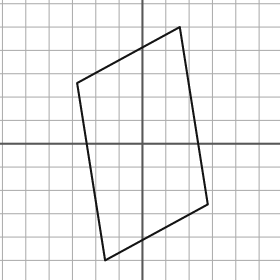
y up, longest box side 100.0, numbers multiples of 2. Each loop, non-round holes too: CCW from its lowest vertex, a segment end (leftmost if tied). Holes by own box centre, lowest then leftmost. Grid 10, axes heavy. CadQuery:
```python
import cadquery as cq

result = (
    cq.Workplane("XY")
    .moveTo(-16.0, -50.0)
    .lineTo(28.0, -26.0)
    .lineTo(16.0, 50.0)
    .lineTo(-28.0, 26.0)
    .close()
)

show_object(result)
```